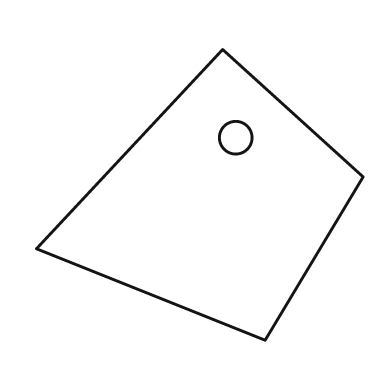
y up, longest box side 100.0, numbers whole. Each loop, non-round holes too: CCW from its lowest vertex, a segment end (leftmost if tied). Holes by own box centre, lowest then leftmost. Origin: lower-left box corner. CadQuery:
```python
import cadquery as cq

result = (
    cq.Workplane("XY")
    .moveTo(70.0, 0.0)
    .lineTo(100.0, 50.0)
    .lineTo(57.0, 89.0)
    .lineTo(0.0, 28.0)
    .close()
    .moveTo(61.0, 62.0)
    .circle(5.0)
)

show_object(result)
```